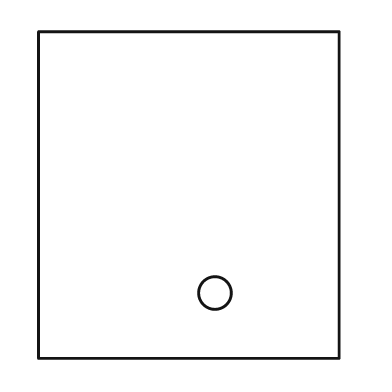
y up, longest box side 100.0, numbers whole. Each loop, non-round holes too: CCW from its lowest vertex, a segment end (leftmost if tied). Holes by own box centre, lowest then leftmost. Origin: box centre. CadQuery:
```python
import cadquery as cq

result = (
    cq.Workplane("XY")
    .moveTo(-46.0, -50.0)
    .lineTo(46.0, -50.0)
    .lineTo(46.0, 50.0)
    .lineTo(-46.0, 50.0)
    .close()
    .moveTo(8.0, -30.0)
    .circle(5.0)
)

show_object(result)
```